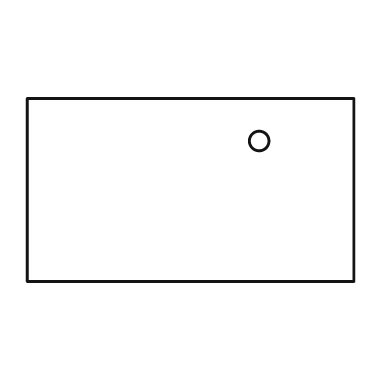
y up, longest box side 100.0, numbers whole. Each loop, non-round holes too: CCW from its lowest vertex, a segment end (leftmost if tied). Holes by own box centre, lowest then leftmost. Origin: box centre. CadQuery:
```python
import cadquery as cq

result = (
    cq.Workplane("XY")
    .moveTo(-50.0, -28.0)
    .lineTo(50.0, -28.0)
    .lineTo(50.0, 28.0)
    .lineTo(-50.0, 28.0)
    .close()
    .moveTo(21.0, 15.0)
    .circle(3.0)
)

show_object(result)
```